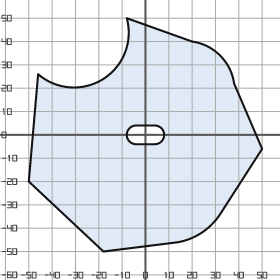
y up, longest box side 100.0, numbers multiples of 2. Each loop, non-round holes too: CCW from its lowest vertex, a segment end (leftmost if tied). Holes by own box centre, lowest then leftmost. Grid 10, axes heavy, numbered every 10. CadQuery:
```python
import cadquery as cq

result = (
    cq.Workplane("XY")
    .moveTo(-18.0, -50.0)
    .lineTo(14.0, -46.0)
    .threePointArc((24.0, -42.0), (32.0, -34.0))
    .lineTo(50.0, -6.0)
    .lineTo(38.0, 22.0)
    .threePointArc((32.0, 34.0), (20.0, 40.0))
    .lineTo(-8.0, 50.0)
    .threePointArc((-18.0, 24.0), (-46.0, 26.0))
    .lineTo(-50.0, -20.0)
    .close()
    .moveTo(-4.0, -4.0)
    .lineTo(4.0, -4.0)
    .threePointArc((8.0, 0.0), (4.0, 4.0))
    .lineTo(-4.0, 4.0)
    .threePointArc((-8.0, 0.0), (-4.0, -4.0))
    .close()
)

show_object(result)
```